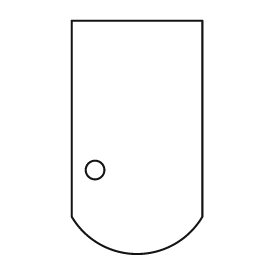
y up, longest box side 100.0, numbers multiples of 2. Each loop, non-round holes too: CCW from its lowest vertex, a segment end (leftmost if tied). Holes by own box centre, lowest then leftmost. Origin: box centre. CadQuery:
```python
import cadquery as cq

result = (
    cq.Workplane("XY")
    .moveTo(-28.0, -34.0)
    .threePointArc((0.0, -50.0), (28.0, -34.0))
    .lineTo(28.0, 50.0)
    .lineTo(-28.0, 50.0)
    .close()
    .moveTo(-18.0, -14.0)
    .circle(4.0)
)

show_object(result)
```